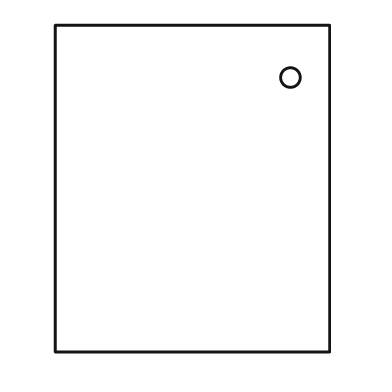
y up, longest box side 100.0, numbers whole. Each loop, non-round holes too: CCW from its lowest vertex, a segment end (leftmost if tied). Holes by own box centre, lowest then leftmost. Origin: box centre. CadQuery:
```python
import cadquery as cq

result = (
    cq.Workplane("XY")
    .moveTo(-42.0, -50.0)
    .lineTo(42.0, -50.0)
    .lineTo(42.0, 50.0)
    .lineTo(-42.0, 50.0)
    .close()
    .moveTo(30.0, 34.0)
    .circle(3.0)
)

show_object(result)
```